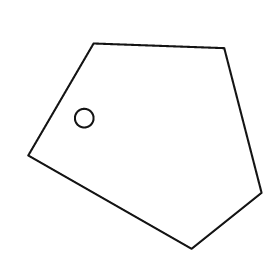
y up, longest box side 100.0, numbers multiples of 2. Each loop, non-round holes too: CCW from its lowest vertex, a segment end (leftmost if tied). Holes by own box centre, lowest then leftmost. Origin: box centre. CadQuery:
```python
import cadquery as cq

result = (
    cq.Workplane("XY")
    .moveTo(20.0, -44.0)
    .lineTo(50.0, -20.0)
    .lineTo(34.0, 42.0)
    .lineTo(-22.0, 44.0)
    .lineTo(-50.0, -4.0)
    .close()
    .moveTo(-26.0, 12.0)
    .circle(4.0)
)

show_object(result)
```